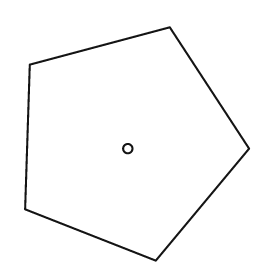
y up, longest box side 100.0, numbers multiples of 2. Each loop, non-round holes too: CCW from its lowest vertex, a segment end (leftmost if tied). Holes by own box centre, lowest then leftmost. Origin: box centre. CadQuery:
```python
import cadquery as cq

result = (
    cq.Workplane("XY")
    .moveTo(8.0, -50.0)
    .lineTo(48.0, -2.0)
    .lineTo(14.0, 50.0)
    .lineTo(-46.0, 34.0)
    .lineTo(-48.0, -28.0)
    .close()
    .moveTo(-4.0, -2.0)
    .circle(2.0)
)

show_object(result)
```